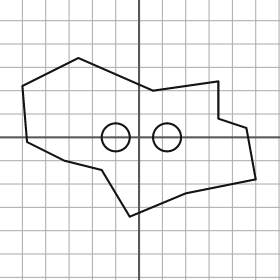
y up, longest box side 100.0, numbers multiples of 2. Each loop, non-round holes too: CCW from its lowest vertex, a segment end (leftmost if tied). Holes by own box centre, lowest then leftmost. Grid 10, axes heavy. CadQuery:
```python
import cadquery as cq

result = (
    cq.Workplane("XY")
    .moveTo(-4.0, -34.0)
    .lineTo(20.0, -24.0)
    .lineTo(50.0, -18.0)
    .lineTo(46.0, 4.0)
    .lineTo(34.0, 8.0)
    .lineTo(34.0, 24.0)
    .lineTo(6.0, 20.0)
    .lineTo(-26.0, 34.0)
    .lineTo(-50.0, 22.0)
    .lineTo(-48.0, -2.0)
    .lineTo(-32.0, -10.0)
    .lineTo(-16.0, -14.0)
    .close()
    .moveTo(-10.0, 0.0)
    .circle(6.0)
    .moveTo(12.0, 0.0)
    .circle(6.0)
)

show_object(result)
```